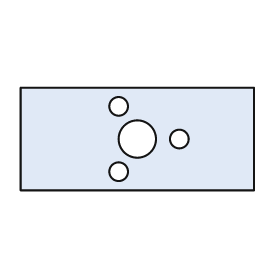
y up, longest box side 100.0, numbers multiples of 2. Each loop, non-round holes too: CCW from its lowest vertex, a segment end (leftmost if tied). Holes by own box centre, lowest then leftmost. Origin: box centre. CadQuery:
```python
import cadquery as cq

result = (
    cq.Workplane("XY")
    .moveTo(-50.0, -22.0)
    .lineTo(50.0, -22.0)
    .lineTo(50.0, 22.0)
    .lineTo(-50.0, 22.0)
    .close()
    .moveTo(-8.0, -14.0)
    .circle(4.0)
    .moveTo(0.0, 0.0)
    .circle(8.0)
    .moveTo(18.0, 0.0)
    .circle(4.0)
    .moveTo(-8.0, 14.0)
    .circle(4.0)
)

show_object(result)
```